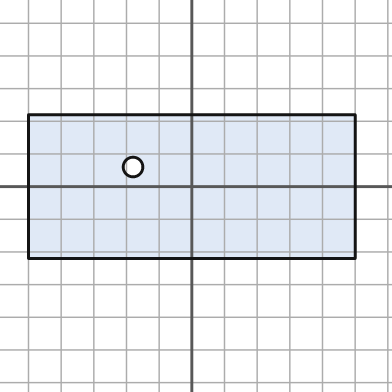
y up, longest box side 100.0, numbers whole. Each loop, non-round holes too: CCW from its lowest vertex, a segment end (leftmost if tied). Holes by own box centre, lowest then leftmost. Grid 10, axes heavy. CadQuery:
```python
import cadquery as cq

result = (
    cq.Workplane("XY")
    .moveTo(-50.0, -22.0)
    .lineTo(50.0, -22.0)
    .lineTo(50.0, 22.0)
    .lineTo(-50.0, 22.0)
    .close()
    .moveTo(-18.0, 6.0)
    .circle(3.0)
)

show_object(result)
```